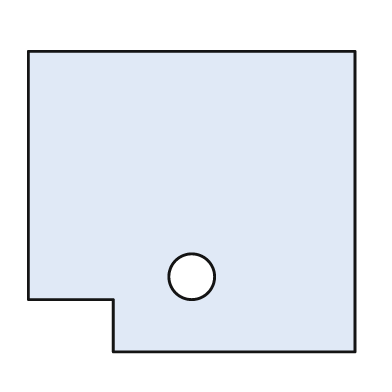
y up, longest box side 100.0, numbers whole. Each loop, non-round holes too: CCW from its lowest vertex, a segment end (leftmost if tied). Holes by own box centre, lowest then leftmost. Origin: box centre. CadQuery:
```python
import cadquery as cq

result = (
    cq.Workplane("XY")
    .moveTo(-24.0, -46.0)
    .lineTo(50.0, -46.0)
    .lineTo(50.0, 46.0)
    .lineTo(-50.0, 46.0)
    .lineTo(-50.0, -30.0)
    .lineTo(-24.0, -30.0)
    .close()
    .moveTo(0.0, -23.0)
    .circle(7.0)
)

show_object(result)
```